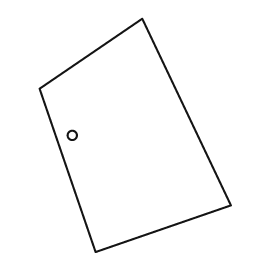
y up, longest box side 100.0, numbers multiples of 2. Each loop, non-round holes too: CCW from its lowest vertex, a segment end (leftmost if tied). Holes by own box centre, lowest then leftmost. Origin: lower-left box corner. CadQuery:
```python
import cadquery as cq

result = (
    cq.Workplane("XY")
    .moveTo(24.0, 0.0)
    .lineTo(82.0, 20.0)
    .lineTo(44.0, 100.0)
    .lineTo(0.0, 70.0)
    .close()
    .moveTo(14.0, 50.0)
    .circle(2.0)
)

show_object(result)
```